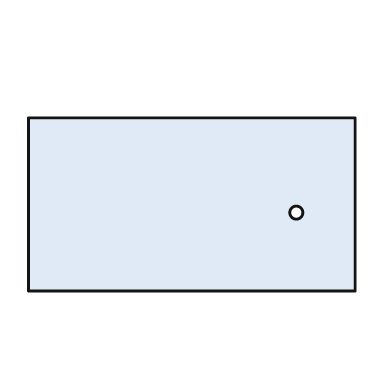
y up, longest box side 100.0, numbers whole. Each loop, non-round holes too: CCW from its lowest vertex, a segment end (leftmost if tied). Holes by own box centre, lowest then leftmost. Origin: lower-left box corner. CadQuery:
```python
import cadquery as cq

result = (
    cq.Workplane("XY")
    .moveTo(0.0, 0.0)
    .lineTo(100.0, 0.0)
    .lineTo(100.0, 53.0)
    .lineTo(0.0, 53.0)
    .close()
    .moveTo(82.0, 24.0)
    .circle(2.0)
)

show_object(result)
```